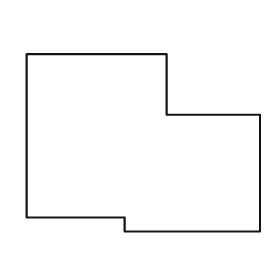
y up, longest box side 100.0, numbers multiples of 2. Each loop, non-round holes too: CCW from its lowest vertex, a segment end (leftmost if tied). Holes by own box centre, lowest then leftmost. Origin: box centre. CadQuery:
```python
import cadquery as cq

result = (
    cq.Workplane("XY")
    .moveTo(-8.0, -38.0)
    .lineTo(50.0, -38.0)
    .lineTo(50.0, 12.0)
    .lineTo(10.0, 12.0)
    .lineTo(10.0, 38.0)
    .lineTo(-50.0, 38.0)
    .lineTo(-50.0, -32.0)
    .lineTo(-8.0, -32.0)
    .close()
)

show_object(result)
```